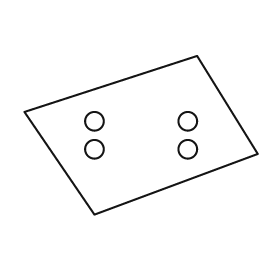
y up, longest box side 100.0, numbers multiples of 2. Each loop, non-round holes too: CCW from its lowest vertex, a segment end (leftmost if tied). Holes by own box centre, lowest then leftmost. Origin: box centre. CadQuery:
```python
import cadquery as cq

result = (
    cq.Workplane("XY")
    .moveTo(-20.0, -34.0)
    .lineTo(50.0, -8.0)
    .lineTo(24.0, 34.0)
    .lineTo(-50.0, 10.0)
    .close()
    .moveTo(-20.0, -6.0)
    .circle(4.0)
    .moveTo(20.0, -6.0)
    .circle(4.0)
    .moveTo(-20.0, 6.0)
    .circle(4.0)
    .moveTo(20.0, 6.0)
    .circle(4.0)
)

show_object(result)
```